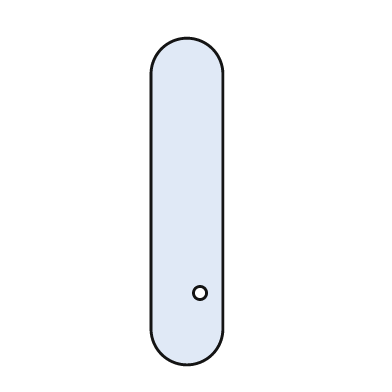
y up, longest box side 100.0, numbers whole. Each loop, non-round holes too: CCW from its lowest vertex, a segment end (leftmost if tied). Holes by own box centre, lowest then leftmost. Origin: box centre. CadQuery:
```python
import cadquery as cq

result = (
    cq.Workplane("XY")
    .moveTo(-11.0, -39.0)
    .threePointArc((0.0, -50.0), (11.0, -39.0))
    .lineTo(11.0, 39.0)
    .threePointArc((0.0, 50.0), (-11.0, 39.0))
    .close()
    .moveTo(4.0, -28.0)
    .circle(2.0)
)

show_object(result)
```